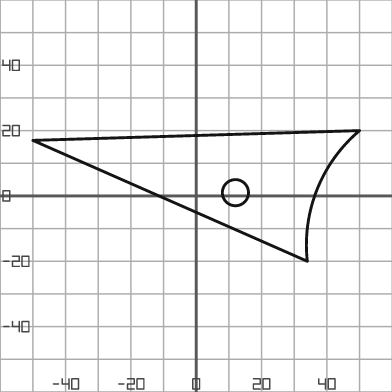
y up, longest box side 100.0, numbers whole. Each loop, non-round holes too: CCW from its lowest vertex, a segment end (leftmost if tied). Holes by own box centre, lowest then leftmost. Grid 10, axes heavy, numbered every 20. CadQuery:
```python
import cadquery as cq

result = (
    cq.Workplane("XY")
    .moveTo(34.0, -20.0)
    .threePointArc((37.0, 2.0), (50.0, 20.0))
    .lineTo(-50.0, 17.0)
    .close()
    .moveTo(12.0, 1.0)
    .circle(4.0)
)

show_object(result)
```